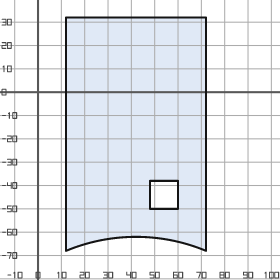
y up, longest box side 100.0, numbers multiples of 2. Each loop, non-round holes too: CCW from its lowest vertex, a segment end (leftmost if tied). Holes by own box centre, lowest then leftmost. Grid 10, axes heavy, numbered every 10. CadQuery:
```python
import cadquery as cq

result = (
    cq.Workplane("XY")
    .moveTo(12.0, -68.0)
    .threePointArc((42.0, -62.0), (72.0, -68.0))
    .lineTo(72.0, 32.0)
    .lineTo(12.0, 32.0)
    .close()
    .moveTo(48.0, -50.0)
    .lineTo(60.0, -50.0)
    .lineTo(60.0, -38.0)
    .lineTo(48.0, -38.0)
    .close()
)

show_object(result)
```